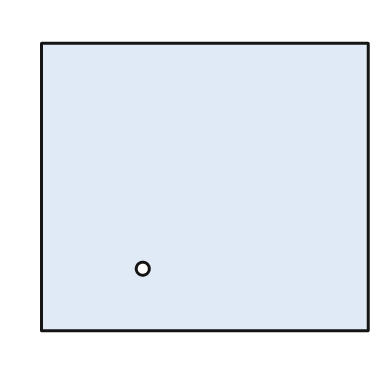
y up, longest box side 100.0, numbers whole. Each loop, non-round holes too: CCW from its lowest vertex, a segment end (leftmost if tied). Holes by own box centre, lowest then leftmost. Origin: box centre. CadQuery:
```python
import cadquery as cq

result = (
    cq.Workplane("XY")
    .moveTo(-50.0, -44.0)
    .lineTo(50.0, -44.0)
    .lineTo(50.0, 44.0)
    .lineTo(-50.0, 44.0)
    .close()
    .moveTo(-19.0, -25.0)
    .circle(2.0)
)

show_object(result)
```